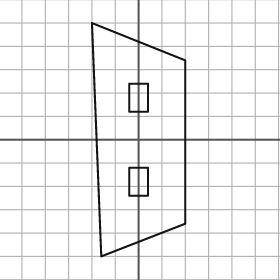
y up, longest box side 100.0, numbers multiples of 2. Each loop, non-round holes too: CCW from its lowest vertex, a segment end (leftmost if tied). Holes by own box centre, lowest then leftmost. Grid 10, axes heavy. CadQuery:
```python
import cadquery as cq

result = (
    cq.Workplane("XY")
    .moveTo(-16.0, -50.0)
    .lineTo(20.0, -36.0)
    .lineTo(20.0, 34.0)
    .lineTo(-20.0, 50.0)
    .close()
    .moveTo(-4.0, -24.0)
    .lineTo(4.0, -24.0)
    .lineTo(4.0, -12.0)
    .lineTo(-4.0, -12.0)
    .close()
    .moveTo(-4.0, 12.0)
    .lineTo(4.0, 12.0)
    .lineTo(4.0, 24.0)
    .lineTo(-4.0, 24.0)
    .close()
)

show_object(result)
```